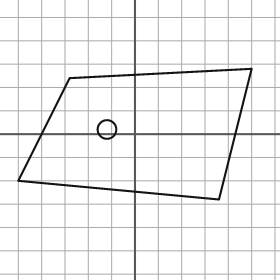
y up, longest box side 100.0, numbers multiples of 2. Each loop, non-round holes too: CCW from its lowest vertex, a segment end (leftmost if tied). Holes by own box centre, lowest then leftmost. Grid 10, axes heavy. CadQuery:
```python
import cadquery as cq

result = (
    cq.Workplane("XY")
    .moveTo(36.0, -28.0)
    .lineTo(50.0, 28.0)
    .lineTo(-28.0, 24.0)
    .lineTo(-50.0, -20.0)
    .close()
    .moveTo(-12.0, 2.0)
    .circle(4.0)
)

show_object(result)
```